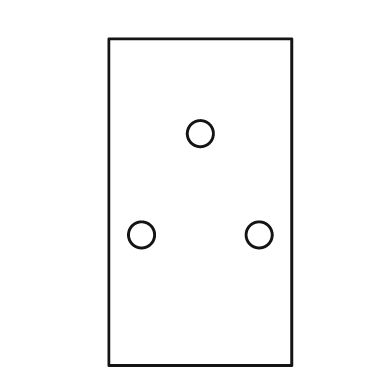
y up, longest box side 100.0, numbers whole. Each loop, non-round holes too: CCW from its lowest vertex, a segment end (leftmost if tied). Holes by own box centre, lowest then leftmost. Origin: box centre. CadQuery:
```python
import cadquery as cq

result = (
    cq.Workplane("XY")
    .moveTo(-28.0, -50.0)
    .lineTo(28.0, -50.0)
    .lineTo(28.0, 50.0)
    .lineTo(-28.0, 50.0)
    .close()
    .moveTo(-18.0, -10.0)
    .circle(4.0)
    .moveTo(18.0, -10.0)
    .circle(4.0)
    .moveTo(0.0, 21.0)
    .circle(4.0)
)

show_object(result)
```